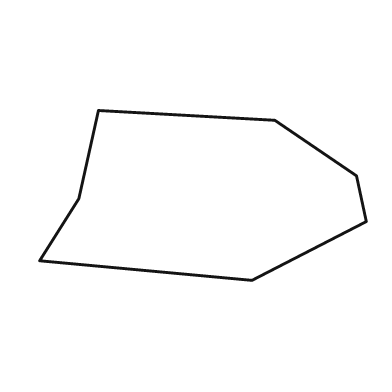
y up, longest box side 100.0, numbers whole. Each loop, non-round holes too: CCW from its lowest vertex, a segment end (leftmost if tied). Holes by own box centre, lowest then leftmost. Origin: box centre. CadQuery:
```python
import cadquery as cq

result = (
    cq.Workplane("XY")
    .moveTo(15.0, -26.0)
    .lineTo(50.0, -8.0)
    .lineTo(47.0, 6.0)
    .lineTo(22.0, 23.0)
    .lineTo(-32.0, 26.0)
    .lineTo(-38.0, -1.0)
    .lineTo(-50.0, -20.0)
    .close()
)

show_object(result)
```